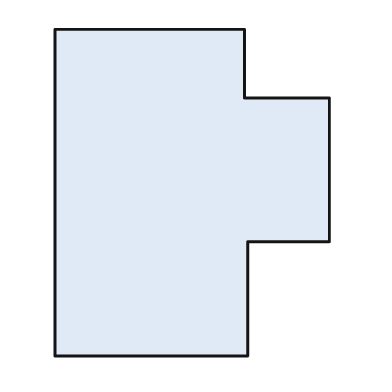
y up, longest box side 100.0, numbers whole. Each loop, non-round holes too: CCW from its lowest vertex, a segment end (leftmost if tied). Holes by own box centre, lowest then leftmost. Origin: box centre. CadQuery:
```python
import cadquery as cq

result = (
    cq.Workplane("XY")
    .moveTo(-42.0, -50.0)
    .lineTo(17.0, -50.0)
    .lineTo(17.0, -15.0)
    .lineTo(42.0, -15.0)
    .lineTo(42.0, 29.0)
    .lineTo(16.0, 29.0)
    .lineTo(16.0, 50.0)
    .lineTo(-42.0, 50.0)
    .close()
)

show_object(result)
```